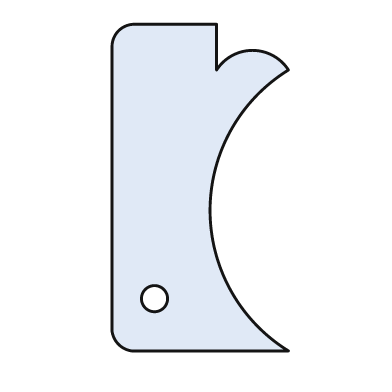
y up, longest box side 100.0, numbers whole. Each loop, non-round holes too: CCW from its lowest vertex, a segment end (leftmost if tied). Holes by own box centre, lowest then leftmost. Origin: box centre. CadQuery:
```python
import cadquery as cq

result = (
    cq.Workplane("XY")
    .moveTo(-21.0, -50.0)
    .lineTo(27.0, -50.0)
    .threePointArc((3.0, -7.0), (27.0, 36.0))
    .threePointArc((16.0, 42.0), (5.0, 36.0))
    .lineTo(5.0, 50.0)
    .lineTo(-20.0, 50.0)
    .threePointArc((-25.0, 48.0), (-27.0, 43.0))
    .lineTo(-27.0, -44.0)
    .threePointArc((-25.0, -48.0), (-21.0, -50.0))
    .close()
    .moveTo(-14.0, -34.0)
    .circle(4.0)
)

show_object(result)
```